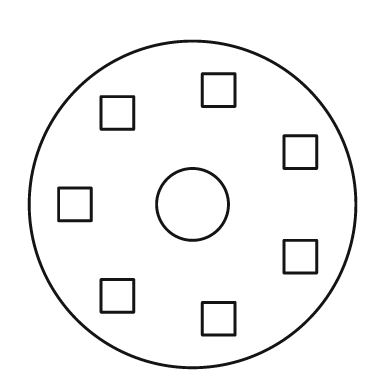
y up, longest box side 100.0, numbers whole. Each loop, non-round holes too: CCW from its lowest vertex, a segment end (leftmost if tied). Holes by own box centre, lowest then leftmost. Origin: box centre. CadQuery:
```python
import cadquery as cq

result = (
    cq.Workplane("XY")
    .moveTo(0.0, 0.0)
    .circle(50.0)
    .moveTo(3.0, -40.0)
    .lineTo(13.0, -40.0)
    .lineTo(13.0, -30.0)
    .lineTo(3.0, -30.0)
    .close()
    .moveTo(-28.0, -33.0)
    .lineTo(-18.0, -33.0)
    .lineTo(-18.0, -23.0)
    .lineTo(-28.0, -23.0)
    .close()
    .moveTo(28.0, -21.0)
    .lineTo(38.0, -21.0)
    .lineTo(38.0, -11.0)
    .lineTo(28.0, -11.0)
    .close()
    .moveTo(-41.0, -5.0)
    .lineTo(-31.0, -5.0)
    .lineTo(-31.0, 5.0)
    .lineTo(-41.0, 5.0)
    .close()
    .moveTo(0.0, 0.0)
    .circle(11.0)
    .moveTo(28.0, 11.0)
    .lineTo(38.0, 11.0)
    .lineTo(38.0, 21.0)
    .lineTo(28.0, 21.0)
    .close()
    .moveTo(-28.0, 23.0)
    .lineTo(-18.0, 23.0)
    .lineTo(-18.0, 33.0)
    .lineTo(-28.0, 33.0)
    .close()
    .moveTo(3.0, 30.0)
    .lineTo(13.0, 30.0)
    .lineTo(13.0, 40.0)
    .lineTo(3.0, 40.0)
    .close()
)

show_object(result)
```